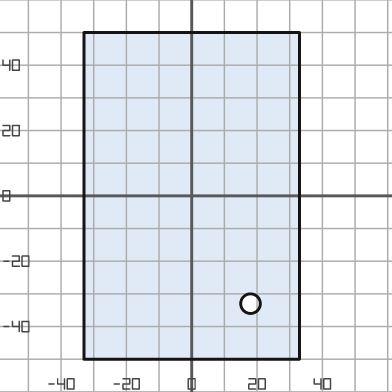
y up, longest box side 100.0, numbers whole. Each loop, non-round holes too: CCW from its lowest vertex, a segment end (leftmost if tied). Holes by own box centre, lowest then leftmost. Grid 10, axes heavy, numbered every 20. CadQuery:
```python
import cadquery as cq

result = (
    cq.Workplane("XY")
    .moveTo(-33.0, -50.0)
    .lineTo(33.0, -50.0)
    .lineTo(33.0, 50.0)
    .lineTo(-33.0, 50.0)
    .close()
    .moveTo(18.0, -33.0)
    .circle(3.0)
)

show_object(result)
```